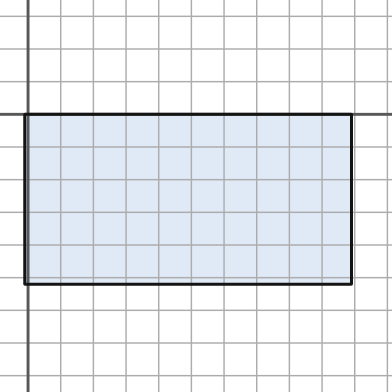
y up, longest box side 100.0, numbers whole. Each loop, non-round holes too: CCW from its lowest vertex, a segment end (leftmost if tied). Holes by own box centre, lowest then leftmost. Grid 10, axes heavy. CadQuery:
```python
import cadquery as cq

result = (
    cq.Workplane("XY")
    .moveTo(-1.0, -52.0)
    .lineTo(99.0, -52.0)
    .lineTo(99.0, 0.0)
    .lineTo(-1.0, 0.0)
    .close()
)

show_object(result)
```